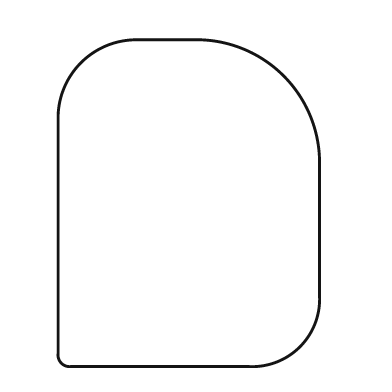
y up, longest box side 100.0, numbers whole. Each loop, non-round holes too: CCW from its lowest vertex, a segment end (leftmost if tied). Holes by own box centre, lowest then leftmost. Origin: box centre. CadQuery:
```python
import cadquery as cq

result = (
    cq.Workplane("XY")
    .moveTo(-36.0, -50.0)
    .lineTo(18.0, -50.0)
    .threePointArc((34.0, -44.0), (40.0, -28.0))
    .lineTo(40.0, 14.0)
    .threePointArc((29.0, 39.0), (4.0, 50.0))
    .lineTo(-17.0, 50.0)
    .threePointArc((-33.0, 43.0), (-40.0, 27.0))
    .lineTo(-40.0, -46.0)
    .threePointArc((-39.0, -49.0), (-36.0, -50.0))
    .close()
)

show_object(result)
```